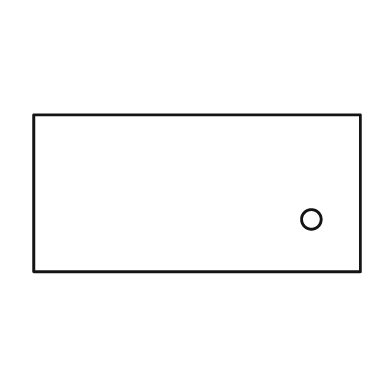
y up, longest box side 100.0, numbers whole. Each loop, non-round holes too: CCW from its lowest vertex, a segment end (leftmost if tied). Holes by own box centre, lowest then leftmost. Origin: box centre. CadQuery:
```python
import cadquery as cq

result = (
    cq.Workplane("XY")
    .moveTo(-50.0, -24.0)
    .lineTo(50.0, -24.0)
    .lineTo(50.0, 24.0)
    .lineTo(-50.0, 24.0)
    .close()
    .moveTo(35.0, -8.0)
    .circle(3.0)
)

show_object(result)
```